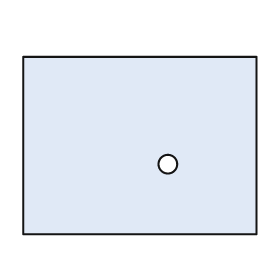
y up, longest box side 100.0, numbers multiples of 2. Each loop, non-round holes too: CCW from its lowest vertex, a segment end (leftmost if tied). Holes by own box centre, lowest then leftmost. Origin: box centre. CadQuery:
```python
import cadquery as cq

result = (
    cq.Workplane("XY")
    .moveTo(-50.0, -38.0)
    .lineTo(50.0, -38.0)
    .lineTo(50.0, 38.0)
    .lineTo(-50.0, 38.0)
    .close()
    .moveTo(12.0, -8.0)
    .circle(4.0)
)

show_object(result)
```